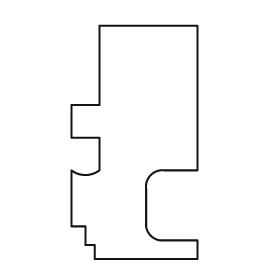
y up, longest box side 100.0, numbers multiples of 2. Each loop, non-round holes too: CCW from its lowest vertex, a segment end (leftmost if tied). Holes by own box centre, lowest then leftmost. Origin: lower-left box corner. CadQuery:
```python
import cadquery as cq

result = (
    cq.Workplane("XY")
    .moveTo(10.0, 0.0)
    .lineTo(54.0, 0.0)
    .lineTo(54.0, 8.0)
    .lineTo(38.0, 8.0)
    .threePointArc((34.0, 10.0), (32.0, 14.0))
    .lineTo(32.0, 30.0)
    .threePointArc((34.0, 36.0), (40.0, 38.0))
    .lineTo(54.0, 38.0)
    .lineTo(54.0, 100.0)
    .lineTo(12.0, 100.0)
    .lineTo(12.0, 66.0)
    .lineTo(0.0, 66.0)
    .lineTo(0.0, 52.0)
    .lineTo(12.0, 52.0)
    .lineTo(12.0, 38.0)
    .threePointArc((6.0, 36.0), (0.0, 38.0))
    .lineTo(0.0, 14.0)
    .lineTo(6.0, 14.0)
    .lineTo(6.0, 6.0)
    .lineTo(10.0, 6.0)
    .close()
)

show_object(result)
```